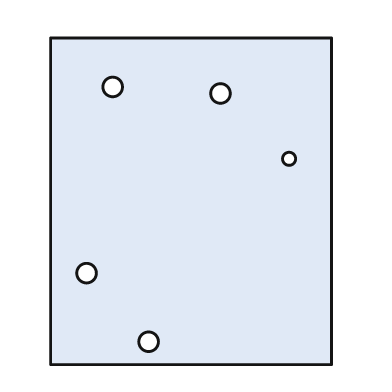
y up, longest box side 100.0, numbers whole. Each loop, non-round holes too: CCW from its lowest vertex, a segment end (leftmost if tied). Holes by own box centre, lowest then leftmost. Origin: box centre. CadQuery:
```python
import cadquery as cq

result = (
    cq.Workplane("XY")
    .moveTo(-43.0, -50.0)
    .lineTo(43.0, -50.0)
    .lineTo(43.0, 50.0)
    .lineTo(-43.0, 50.0)
    .close()
    .moveTo(-13.0, -43.0)
    .circle(3.0)
    .moveTo(-32.0, -22.0)
    .circle(3.0)
    .moveTo(30.0, 13.0)
    .circle(2.0)
    .moveTo(9.0, 33.0)
    .circle(3.0)
    .moveTo(-24.0, 35.0)
    .circle(3.0)
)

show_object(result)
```